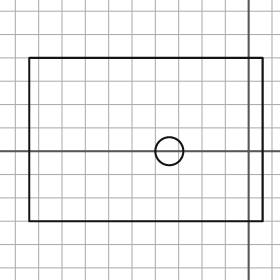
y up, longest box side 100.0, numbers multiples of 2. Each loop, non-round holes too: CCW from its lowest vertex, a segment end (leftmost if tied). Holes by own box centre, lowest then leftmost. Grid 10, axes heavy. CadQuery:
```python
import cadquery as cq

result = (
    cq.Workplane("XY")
    .moveTo(-94.0, -30.0)
    .lineTo(6.0, -30.0)
    .lineTo(6.0, 40.0)
    .lineTo(-94.0, 40.0)
    .close()
    .moveTo(-34.0, 0.0)
    .circle(6.0)
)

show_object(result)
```